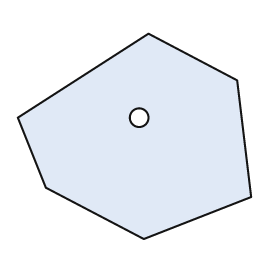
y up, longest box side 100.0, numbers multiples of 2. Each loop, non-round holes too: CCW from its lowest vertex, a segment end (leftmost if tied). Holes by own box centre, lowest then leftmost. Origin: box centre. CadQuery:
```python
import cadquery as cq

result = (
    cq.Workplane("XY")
    .moveTo(4.0, -44.0)
    .lineTo(50.0, -26.0)
    .lineTo(44.0, 24.0)
    .lineTo(6.0, 44.0)
    .lineTo(-50.0, 8.0)
    .lineTo(-38.0, -22.0)
    .close()
    .moveTo(2.0, 8.0)
    .circle(4.0)
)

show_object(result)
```